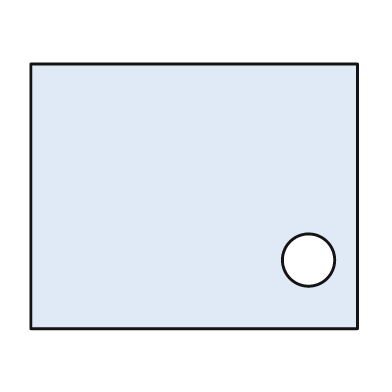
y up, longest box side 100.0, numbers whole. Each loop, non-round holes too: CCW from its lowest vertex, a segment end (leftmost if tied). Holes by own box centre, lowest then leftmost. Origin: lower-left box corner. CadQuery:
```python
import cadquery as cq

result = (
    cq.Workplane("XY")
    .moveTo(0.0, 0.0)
    .lineTo(100.0, 0.0)
    .lineTo(100.0, 81.0)
    .lineTo(0.0, 81.0)
    .close()
    .moveTo(85.0, 21.0)
    .circle(8.0)
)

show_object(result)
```